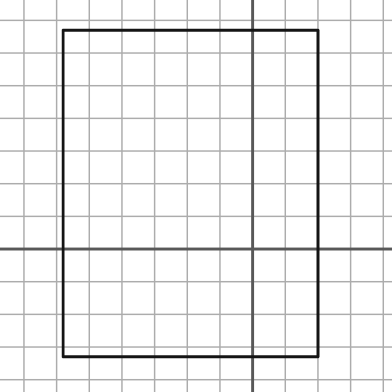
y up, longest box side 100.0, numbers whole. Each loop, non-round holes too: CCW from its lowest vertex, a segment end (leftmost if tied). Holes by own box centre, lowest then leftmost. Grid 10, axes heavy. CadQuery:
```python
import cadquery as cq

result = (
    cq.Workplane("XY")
    .moveTo(-58.0, -33.0)
    .lineTo(20.0, -33.0)
    .lineTo(20.0, 67.0)
    .lineTo(-58.0, 67.0)
    .close()
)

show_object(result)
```